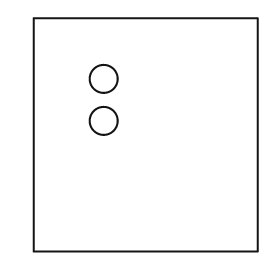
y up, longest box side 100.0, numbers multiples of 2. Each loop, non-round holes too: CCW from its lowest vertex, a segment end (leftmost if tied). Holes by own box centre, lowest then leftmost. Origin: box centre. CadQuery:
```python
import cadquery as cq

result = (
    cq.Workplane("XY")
    .moveTo(-48.0, -50.0)
    .lineTo(48.0, -50.0)
    .lineTo(48.0, 50.0)
    .lineTo(-48.0, 50.0)
    .close()
    .moveTo(-18.0, 6.0)
    .circle(6.0)
    .moveTo(-18.0, 24.0)
    .circle(6.0)
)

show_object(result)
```